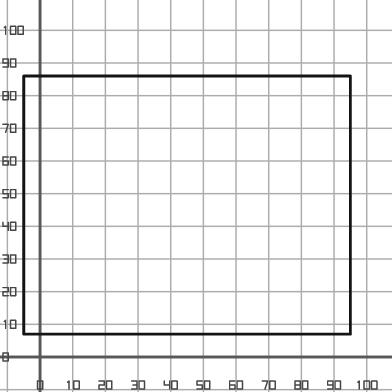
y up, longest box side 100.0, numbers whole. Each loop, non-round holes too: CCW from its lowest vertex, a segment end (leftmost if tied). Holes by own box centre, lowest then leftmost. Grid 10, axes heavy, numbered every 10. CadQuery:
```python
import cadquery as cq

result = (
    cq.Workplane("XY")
    .moveTo(-5.0, 7.0)
    .lineTo(95.0, 7.0)
    .lineTo(95.0, 86.0)
    .lineTo(-5.0, 86.0)
    .close()
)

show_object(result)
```